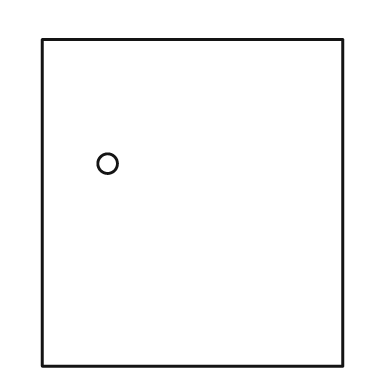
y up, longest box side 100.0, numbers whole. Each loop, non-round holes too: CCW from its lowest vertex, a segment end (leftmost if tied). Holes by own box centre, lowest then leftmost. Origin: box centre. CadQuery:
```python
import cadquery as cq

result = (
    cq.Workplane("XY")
    .moveTo(-46.0, -50.0)
    .lineTo(46.0, -50.0)
    .lineTo(46.0, 50.0)
    .lineTo(-46.0, 50.0)
    .close()
    .moveTo(-26.0, 12.0)
    .circle(3.0)
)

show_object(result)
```